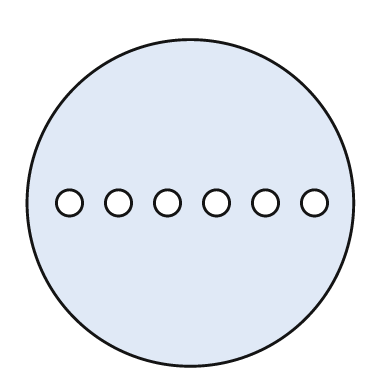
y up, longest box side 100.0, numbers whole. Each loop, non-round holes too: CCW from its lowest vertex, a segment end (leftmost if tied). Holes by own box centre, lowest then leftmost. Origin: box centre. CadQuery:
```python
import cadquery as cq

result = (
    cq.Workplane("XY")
    .moveTo(0.0, 0.0)
    .circle(50.0)
    .moveTo(-37.0, 0.0)
    .circle(4.0)
    .moveTo(-22.0, 0.0)
    .circle(4.0)
    .moveTo(-7.0, 0.0)
    .circle(4.0)
    .moveTo(8.0, 0.0)
    .circle(4.0)
    .moveTo(23.0, 0.0)
    .circle(4.0)
    .moveTo(38.0, 0.0)
    .circle(4.0)
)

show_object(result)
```